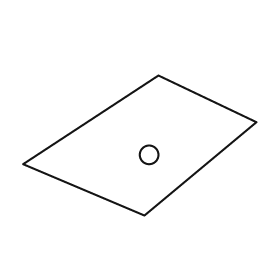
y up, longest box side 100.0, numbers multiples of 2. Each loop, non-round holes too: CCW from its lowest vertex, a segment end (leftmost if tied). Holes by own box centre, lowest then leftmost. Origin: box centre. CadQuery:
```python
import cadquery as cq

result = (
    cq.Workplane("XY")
    .moveTo(2.0, -30.0)
    .lineTo(50.0, 10.0)
    .lineTo(8.0, 30.0)
    .lineTo(-50.0, -8.0)
    .close()
    .moveTo(4.0, -4.0)
    .circle(4.0)
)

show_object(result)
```